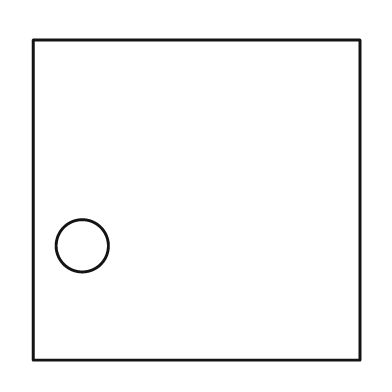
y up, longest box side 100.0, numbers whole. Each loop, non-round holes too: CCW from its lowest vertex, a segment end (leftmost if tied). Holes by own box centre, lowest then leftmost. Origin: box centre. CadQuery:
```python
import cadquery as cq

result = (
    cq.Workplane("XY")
    .moveTo(-50.0, -49.0)
    .lineTo(50.0, -49.0)
    .lineTo(50.0, 49.0)
    .lineTo(-50.0, 49.0)
    .close()
    .moveTo(-35.0, -14.0)
    .circle(8.0)
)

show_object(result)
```